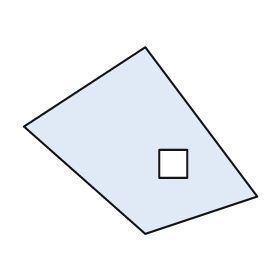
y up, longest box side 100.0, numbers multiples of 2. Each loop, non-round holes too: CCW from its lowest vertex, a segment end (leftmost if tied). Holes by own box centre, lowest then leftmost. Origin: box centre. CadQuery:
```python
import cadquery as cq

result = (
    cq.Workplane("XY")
    .moveTo(2.0, -40.0)
    .lineTo(50.0, -24.0)
    .lineTo(2.0, 40.0)
    .lineTo(-50.0, 6.0)
    .close()
    .moveTo(8.0, -16.0)
    .lineTo(20.0, -16.0)
    .lineTo(20.0, -4.0)
    .lineTo(8.0, -4.0)
    .close()
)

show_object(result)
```